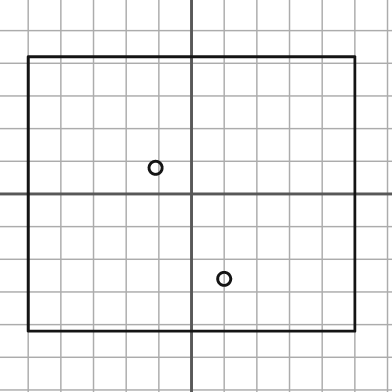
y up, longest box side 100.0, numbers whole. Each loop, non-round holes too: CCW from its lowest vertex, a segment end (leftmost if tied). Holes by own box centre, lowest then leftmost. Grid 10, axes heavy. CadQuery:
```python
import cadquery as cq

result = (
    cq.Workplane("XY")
    .moveTo(-50.0, -42.0)
    .lineTo(50.0, -42.0)
    .lineTo(50.0, 42.0)
    .lineTo(-50.0, 42.0)
    .close()
    .moveTo(10.0, -26.0)
    .circle(2.0)
    .moveTo(-11.0, 8.0)
    .circle(2.0)
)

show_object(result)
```